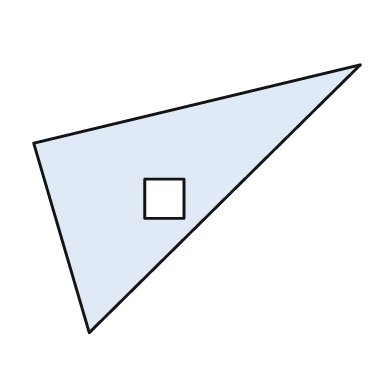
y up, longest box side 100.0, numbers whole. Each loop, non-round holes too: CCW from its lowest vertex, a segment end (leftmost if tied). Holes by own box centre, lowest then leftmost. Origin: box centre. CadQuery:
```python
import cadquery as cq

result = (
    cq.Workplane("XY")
    .moveTo(-33.0, -41.0)
    .lineTo(50.0, 41.0)
    .lineTo(-50.0, 17.0)
    .close()
    .moveTo(-16.0, -6.0)
    .lineTo(-4.0, -6.0)
    .lineTo(-4.0, 6.0)
    .lineTo(-16.0, 6.0)
    .close()
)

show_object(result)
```